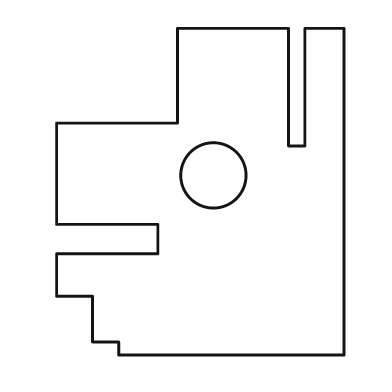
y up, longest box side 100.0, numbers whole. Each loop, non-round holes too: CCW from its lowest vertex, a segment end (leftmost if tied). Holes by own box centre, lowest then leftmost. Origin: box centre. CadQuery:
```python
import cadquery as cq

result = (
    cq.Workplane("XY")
    .moveTo(-25.0, -50.0)
    .lineTo(44.0, -50.0)
    .lineTo(44.0, 50.0)
    .lineTo(32.0, 50.0)
    .lineTo(32.0, 14.0)
    .lineTo(27.0, 14.0)
    .lineTo(27.0, 50.0)
    .lineTo(-7.0, 50.0)
    .lineTo(-7.0, 21.0)
    .lineTo(-44.0, 21.0)
    .lineTo(-44.0, -10.0)
    .lineTo(-13.0, -10.0)
    .lineTo(-13.0, -19.0)
    .lineTo(-44.0, -19.0)
    .lineTo(-44.0, -32.0)
    .lineTo(-33.0, -32.0)
    .lineTo(-33.0, -46.0)
    .lineTo(-25.0, -46.0)
    .close()
    .moveTo(4.0, 5.0)
    .circle(10.0)
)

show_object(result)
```